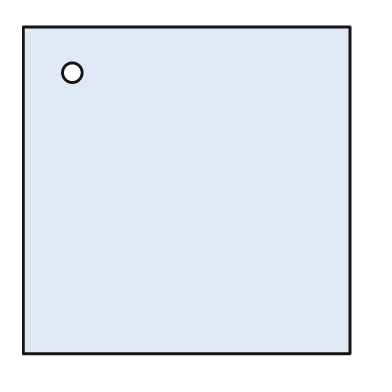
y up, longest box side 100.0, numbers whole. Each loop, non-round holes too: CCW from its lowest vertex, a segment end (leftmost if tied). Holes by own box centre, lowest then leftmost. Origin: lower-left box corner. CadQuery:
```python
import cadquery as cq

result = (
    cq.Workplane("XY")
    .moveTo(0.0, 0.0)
    .lineTo(100.0, 0.0)
    .lineTo(100.0, 100.0)
    .lineTo(0.0, 100.0)
    .close()
    .moveTo(15.0, 86.0)
    .circle(3.0)
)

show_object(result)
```